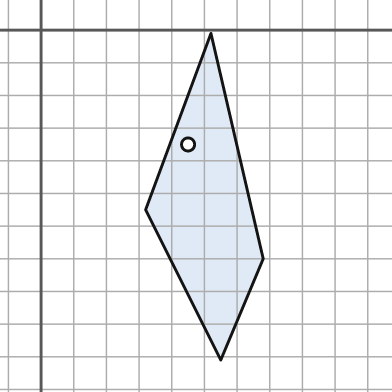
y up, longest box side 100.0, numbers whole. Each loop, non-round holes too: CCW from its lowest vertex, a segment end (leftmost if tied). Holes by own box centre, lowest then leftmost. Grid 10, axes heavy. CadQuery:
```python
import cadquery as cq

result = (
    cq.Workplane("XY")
    .moveTo(55.0, -101.0)
    .lineTo(68.0, -70.0)
    .lineTo(52.0, -1.0)
    .lineTo(32.0, -55.0)
    .close()
    .moveTo(45.0, -35.0)
    .circle(2.0)
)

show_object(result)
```